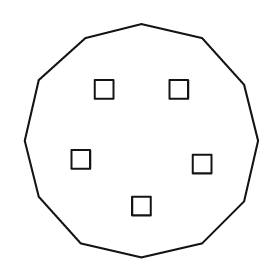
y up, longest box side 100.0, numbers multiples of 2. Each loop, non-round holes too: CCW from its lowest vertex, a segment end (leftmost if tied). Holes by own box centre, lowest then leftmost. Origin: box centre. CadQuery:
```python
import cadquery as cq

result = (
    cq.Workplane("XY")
    .moveTo(0.0, -50.0)
    .lineTo(26.0, -44.0)
    .lineTo(44.0, -26.0)
    .lineTo(50.0, 0.0)
    .lineTo(44.0, 24.0)
    .lineTo(26.0, 44.0)
    .lineTo(0.0, 50.0)
    .lineTo(-24.0, 44.0)
    .lineTo(-44.0, 26.0)
    .lineTo(-50.0, 0.0)
    .lineTo(-44.0, -24.0)
    .lineTo(-26.0, -44.0)
    .close()
    .moveTo(-4.0, -32.0)
    .lineTo(4.0, -32.0)
    .lineTo(4.0, -24.0)
    .lineTo(-4.0, -24.0)
    .close()
    .moveTo(22.0, -14.0)
    .lineTo(30.0, -14.0)
    .lineTo(30.0, -6.0)
    .lineTo(22.0, -6.0)
    .close()
    .moveTo(-30.0, -12.0)
    .lineTo(-22.0, -12.0)
    .lineTo(-22.0, -4.0)
    .lineTo(-30.0, -4.0)
    .close()
    .moveTo(-20.0, 18.0)
    .lineTo(-12.0, 18.0)
    .lineTo(-12.0, 26.0)
    .lineTo(-20.0, 26.0)
    .close()
    .moveTo(12.0, 18.0)
    .lineTo(20.0, 18.0)
    .lineTo(20.0, 26.0)
    .lineTo(12.0, 26.0)
    .close()
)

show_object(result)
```